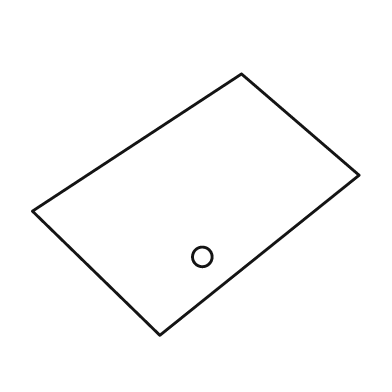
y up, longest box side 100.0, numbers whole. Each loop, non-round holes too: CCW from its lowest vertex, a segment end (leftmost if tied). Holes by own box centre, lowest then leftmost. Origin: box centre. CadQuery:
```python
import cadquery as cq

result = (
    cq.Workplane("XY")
    .moveTo(-11.0, -40.0)
    .lineTo(50.0, 9.0)
    .lineTo(14.0, 40.0)
    .lineTo(-50.0, -2.0)
    .close()
    .moveTo(2.0, -16.0)
    .circle(3.0)
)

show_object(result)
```